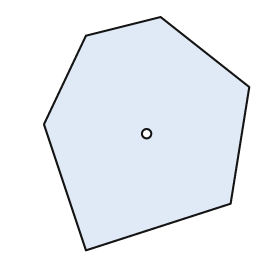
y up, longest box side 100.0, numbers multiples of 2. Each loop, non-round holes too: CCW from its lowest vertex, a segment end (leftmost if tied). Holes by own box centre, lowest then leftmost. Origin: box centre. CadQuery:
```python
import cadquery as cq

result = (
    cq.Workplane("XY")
    .moveTo(-26.0, -50.0)
    .lineTo(36.0, -30.0)
    .lineTo(44.0, 20.0)
    .lineTo(6.0, 50.0)
    .lineTo(-26.0, 42.0)
    .lineTo(-44.0, 4.0)
    .close()
    .moveTo(0.0, 0.0)
    .circle(2.0)
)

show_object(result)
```